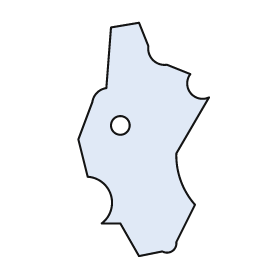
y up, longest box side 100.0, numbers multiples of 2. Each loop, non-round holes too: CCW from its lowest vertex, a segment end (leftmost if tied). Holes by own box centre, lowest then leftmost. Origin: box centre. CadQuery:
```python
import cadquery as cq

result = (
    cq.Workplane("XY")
    .moveTo(-2.0, -50.0)
    .lineTo(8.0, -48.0)
    .threePointArc((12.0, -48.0), (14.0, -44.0))
    .lineTo(22.0, -28.0)
    .threePointArc((16.0, -18.0), (14.0, -6.0))
    .lineTo(28.0, 18.0)
    .threePointArc((20.0, 20.0), (20.0, 28.0))
    .lineTo(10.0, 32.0)
    .threePointArc((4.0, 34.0), (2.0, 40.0))
    .lineTo(-2.0, 50.0)
    .lineTo(-14.0, 48.0)
    .lineTo(-16.0, 22.0)
    .threePointArc((-20.0, 20.0), (-22.0, 16.0))
    .lineTo(-28.0, 0.0)
    .lineTo(-24.0, -16.0)
    .threePointArc((-14.0, -24.0), (-18.0, -36.0))
    .lineTo(-10.0, -36.0)
    .close()
    .moveTo(-10.0, 6.0)
    .circle(4.0)
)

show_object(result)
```